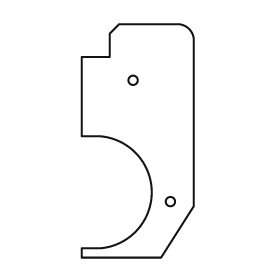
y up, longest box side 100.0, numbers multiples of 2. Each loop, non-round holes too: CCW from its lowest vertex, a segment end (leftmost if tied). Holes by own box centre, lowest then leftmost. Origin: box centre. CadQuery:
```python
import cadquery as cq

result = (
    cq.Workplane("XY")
    .moveTo(-24.0, -50.0)
    .lineTo(10.0, -50.0)
    .lineTo(24.0, -28.0)
    .lineTo(24.0, 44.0)
    .threePointArc((22.0, 48.0), (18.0, 50.0))
    .lineTo(-8.0, 50.0)
    .lineTo(-12.0, 46.0)
    .lineTo(-12.0, 36.0)
    .lineTo(-24.0, 36.0)
    .lineTo(-24.0, 2.0)
    .lineTo(-16.0, 2.0)
    .threePointArc((6.0, -22.0), (-16.0, -46.0))
    .lineTo(-24.0, -46.0)
    .close()
    .moveTo(14.0, -26.0)
    .circle(2.0)
    .moveTo(-2.0, 26.0)
    .circle(2.0)
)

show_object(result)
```